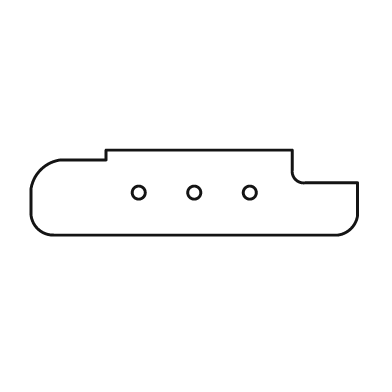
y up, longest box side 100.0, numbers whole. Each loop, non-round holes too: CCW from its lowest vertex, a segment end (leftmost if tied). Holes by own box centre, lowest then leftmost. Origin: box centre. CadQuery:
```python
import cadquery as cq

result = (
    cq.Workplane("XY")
    .moveTo(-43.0, -13.0)
    .lineTo(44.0, -13.0)
    .threePointArc((48.0, -11.0), (50.0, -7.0))
    .lineTo(50.0, 3.0)
    .lineTo(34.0, 3.0)
    .threePointArc((31.0, 4.0), (30.0, 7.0))
    .lineTo(30.0, 13.0)
    .lineTo(-27.0, 13.0)
    .lineTo(-27.0, 10.0)
    .lineTo(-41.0, 10.0)
    .threePointArc((-47.0, 7.0), (-50.0, 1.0))
    .lineTo(-50.0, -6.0)
    .threePointArc((-48.0, -11.0), (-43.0, -13.0))
    .close()
    .moveTo(-17.0, 0.0)
    .circle(2.0)
    .moveTo(0.0, 0.0)
    .circle(2.0)
    .moveTo(17.0, 0.0)
    .circle(2.0)
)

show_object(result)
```